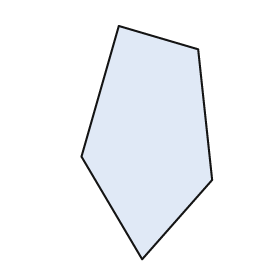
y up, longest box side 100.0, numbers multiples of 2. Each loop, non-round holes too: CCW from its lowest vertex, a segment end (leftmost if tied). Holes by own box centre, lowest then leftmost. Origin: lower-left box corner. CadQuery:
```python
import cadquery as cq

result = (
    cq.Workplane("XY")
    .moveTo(26.0, 0.0)
    .lineTo(56.0, 34.0)
    .lineTo(50.0, 90.0)
    .lineTo(16.0, 100.0)
    .lineTo(0.0, 44.0)
    .close()
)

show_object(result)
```